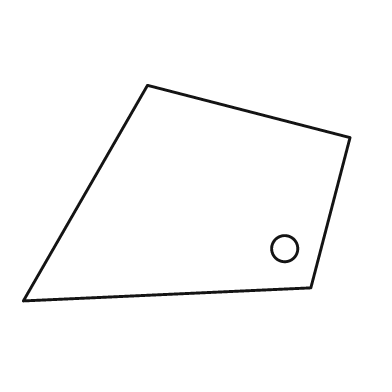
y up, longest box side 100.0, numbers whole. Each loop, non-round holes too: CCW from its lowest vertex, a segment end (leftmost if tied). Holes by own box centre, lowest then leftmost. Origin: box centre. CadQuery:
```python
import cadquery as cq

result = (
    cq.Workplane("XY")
    .moveTo(-50.0, -33.0)
    .lineTo(38.0, -29.0)
    .lineTo(50.0, 17.0)
    .lineTo(-12.0, 33.0)
    .close()
    .moveTo(30.0, -17.0)
    .circle(4.0)
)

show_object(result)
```